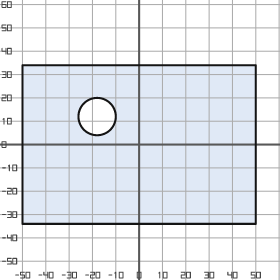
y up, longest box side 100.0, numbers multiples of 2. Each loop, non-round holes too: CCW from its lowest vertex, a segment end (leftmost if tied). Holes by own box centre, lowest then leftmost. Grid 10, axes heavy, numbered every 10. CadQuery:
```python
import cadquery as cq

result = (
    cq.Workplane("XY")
    .moveTo(-50.0, -34.0)
    .lineTo(50.0, -34.0)
    .lineTo(50.0, 34.0)
    .lineTo(-50.0, 34.0)
    .close()
    .moveTo(-18.0, 12.0)
    .circle(8.0)
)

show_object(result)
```